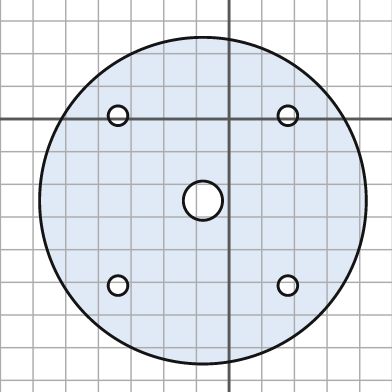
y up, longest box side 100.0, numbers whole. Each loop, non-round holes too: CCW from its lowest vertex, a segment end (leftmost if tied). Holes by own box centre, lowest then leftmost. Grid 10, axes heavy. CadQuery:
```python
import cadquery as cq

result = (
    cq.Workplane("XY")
    .moveTo(-8.0, -25.0)
    .circle(50.0)
    .moveTo(-34.0, -51.0)
    .circle(3.0)
    .moveTo(18.0, -51.0)
    .circle(3.0)
    .moveTo(-8.0, -25.0)
    .circle(6.0)
    .moveTo(-34.0, 1.0)
    .circle(3.0)
    .moveTo(18.0, 1.0)
    .circle(3.0)
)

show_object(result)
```